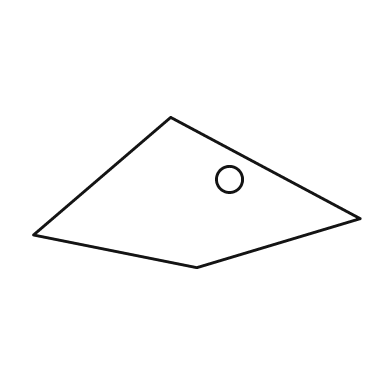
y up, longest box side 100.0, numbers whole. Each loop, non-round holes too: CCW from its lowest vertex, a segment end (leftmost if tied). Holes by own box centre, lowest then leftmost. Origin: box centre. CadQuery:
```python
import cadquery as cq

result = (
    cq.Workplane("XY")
    .moveTo(0.0, -23.0)
    .lineTo(50.0, -8.0)
    .lineTo(-8.0, 23.0)
    .lineTo(-50.0, -13.0)
    .close()
    .moveTo(10.0, 4.0)
    .circle(4.0)
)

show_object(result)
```